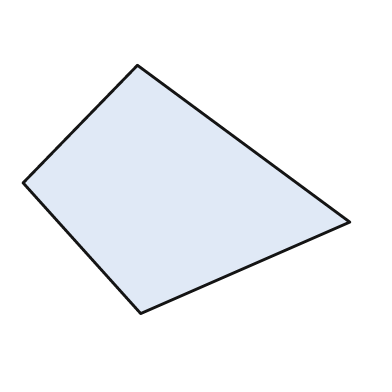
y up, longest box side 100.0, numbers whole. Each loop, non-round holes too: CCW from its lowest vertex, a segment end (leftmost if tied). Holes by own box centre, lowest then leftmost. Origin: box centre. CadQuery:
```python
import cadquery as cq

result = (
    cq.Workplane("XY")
    .moveTo(-14.0, -38.0)
    .lineTo(50.0, -10.0)
    .lineTo(-15.0, 38.0)
    .lineTo(-50.0, 2.0)
    .close()
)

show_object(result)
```